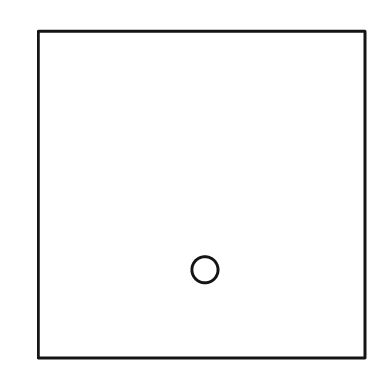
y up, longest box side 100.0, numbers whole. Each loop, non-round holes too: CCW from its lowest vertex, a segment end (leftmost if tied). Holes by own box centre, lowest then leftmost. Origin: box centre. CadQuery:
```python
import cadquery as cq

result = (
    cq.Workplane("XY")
    .moveTo(-50.0, -50.0)
    .lineTo(50.0, -50.0)
    .lineTo(50.0, 50.0)
    .lineTo(-50.0, 50.0)
    .close()
    .moveTo(1.0, -23.0)
    .circle(4.0)
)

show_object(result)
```